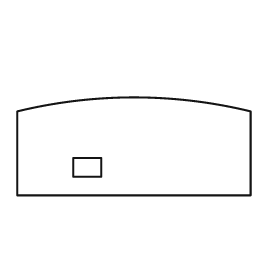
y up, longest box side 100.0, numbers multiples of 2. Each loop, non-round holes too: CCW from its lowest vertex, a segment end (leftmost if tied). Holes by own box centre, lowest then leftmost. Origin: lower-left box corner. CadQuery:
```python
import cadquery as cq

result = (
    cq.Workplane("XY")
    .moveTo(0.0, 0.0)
    .lineTo(100.0, 0.0)
    .lineTo(100.0, 36.0)
    .threePointArc((50.0, 42.0), (0.0, 36.0))
    .close()
    .moveTo(24.0, 8.0)
    .lineTo(36.0, 8.0)
    .lineTo(36.0, 16.0)
    .lineTo(24.0, 16.0)
    .close()
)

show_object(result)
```